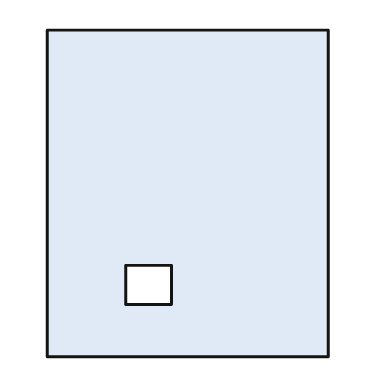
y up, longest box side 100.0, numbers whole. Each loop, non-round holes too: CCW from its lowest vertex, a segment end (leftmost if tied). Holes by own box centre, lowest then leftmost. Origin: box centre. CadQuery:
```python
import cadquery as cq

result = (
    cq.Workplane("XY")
    .moveTo(-43.0, -50.0)
    .lineTo(43.0, -50.0)
    .lineTo(43.0, 50.0)
    .lineTo(-43.0, 50.0)
    .close()
    .moveTo(-19.0, -34.0)
    .lineTo(-5.0, -34.0)
    .lineTo(-5.0, -22.0)
    .lineTo(-19.0, -22.0)
    .close()
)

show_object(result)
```